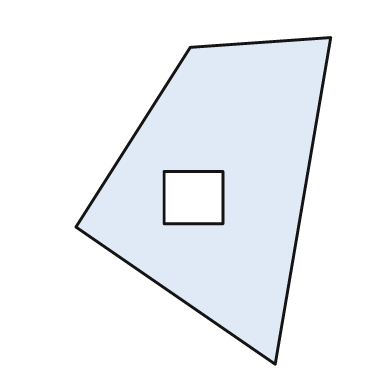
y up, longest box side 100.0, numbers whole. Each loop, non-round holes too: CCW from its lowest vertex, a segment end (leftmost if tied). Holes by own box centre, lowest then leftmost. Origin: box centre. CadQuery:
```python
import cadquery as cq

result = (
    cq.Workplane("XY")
    .moveTo(22.0, -50.0)
    .lineTo(39.0, 50.0)
    .lineTo(-4.0, 47.0)
    .lineTo(-39.0, -8.0)
    .close()
    .moveTo(-12.0, -7.0)
    .lineTo(6.0, -7.0)
    .lineTo(6.0, 9.0)
    .lineTo(-12.0, 9.0)
    .close()
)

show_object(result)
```